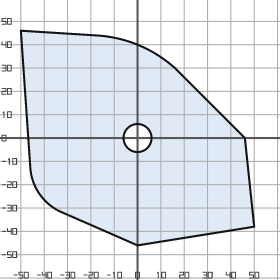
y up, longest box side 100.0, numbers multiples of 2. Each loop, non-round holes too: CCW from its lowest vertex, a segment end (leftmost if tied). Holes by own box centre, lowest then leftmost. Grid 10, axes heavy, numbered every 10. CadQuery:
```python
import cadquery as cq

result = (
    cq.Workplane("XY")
    .moveTo(0.0, -46.0)
    .lineTo(50.0, -38.0)
    .lineTo(46.0, 0.0)
    .lineTo(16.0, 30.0)
    .threePointArc((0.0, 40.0), (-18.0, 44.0))
    .lineTo(-50.0, 46.0)
    .lineTo(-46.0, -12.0)
    .threePointArc((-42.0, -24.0), (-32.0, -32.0))
    .close()
    .moveTo(0.0, 0.0)
    .circle(6.0)
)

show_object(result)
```